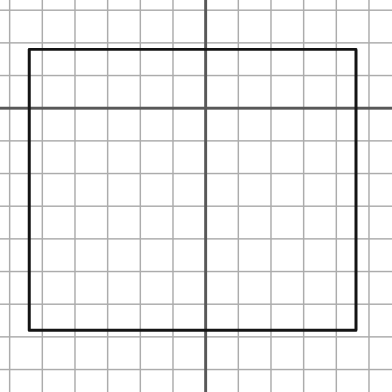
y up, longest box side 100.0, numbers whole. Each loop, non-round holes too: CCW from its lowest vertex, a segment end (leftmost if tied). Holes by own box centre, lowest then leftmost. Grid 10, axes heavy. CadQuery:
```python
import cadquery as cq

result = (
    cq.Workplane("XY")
    .moveTo(-54.0, -68.0)
    .lineTo(46.0, -68.0)
    .lineTo(46.0, 18.0)
    .lineTo(-54.0, 18.0)
    .close()
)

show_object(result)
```